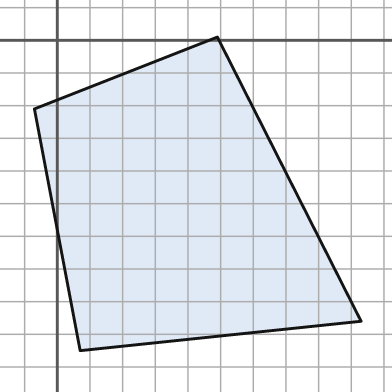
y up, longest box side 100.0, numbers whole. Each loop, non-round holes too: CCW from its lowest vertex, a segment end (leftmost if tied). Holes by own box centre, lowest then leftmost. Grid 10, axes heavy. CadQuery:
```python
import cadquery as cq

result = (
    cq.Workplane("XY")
    .moveTo(7.0, -95.0)
    .lineTo(93.0, -86.0)
    .lineTo(49.0, 1.0)
    .lineTo(-7.0, -21.0)
    .close()
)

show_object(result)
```